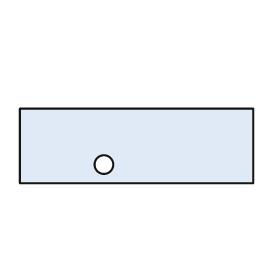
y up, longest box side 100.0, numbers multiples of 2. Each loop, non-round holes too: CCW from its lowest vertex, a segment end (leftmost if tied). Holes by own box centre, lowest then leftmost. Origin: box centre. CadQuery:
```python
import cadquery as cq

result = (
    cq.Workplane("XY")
    .moveTo(-50.0, -16.0)
    .lineTo(50.0, -16.0)
    .lineTo(50.0, 16.0)
    .lineTo(-50.0, 16.0)
    .close()
    .moveTo(-14.0, -8.0)
    .circle(4.0)
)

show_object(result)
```